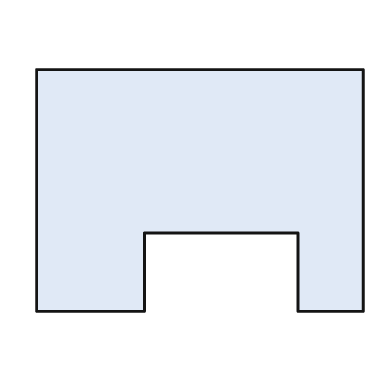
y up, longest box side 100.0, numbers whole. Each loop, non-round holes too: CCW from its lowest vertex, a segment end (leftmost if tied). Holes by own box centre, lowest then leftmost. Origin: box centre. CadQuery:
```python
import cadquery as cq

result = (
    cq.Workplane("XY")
    .moveTo(-50.0, -37.0)
    .lineTo(-17.0, -37.0)
    .lineTo(-17.0, -13.0)
    .lineTo(30.0, -13.0)
    .lineTo(30.0, -37.0)
    .lineTo(50.0, -37.0)
    .lineTo(50.0, 37.0)
    .lineTo(-50.0, 37.0)
    .close()
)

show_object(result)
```